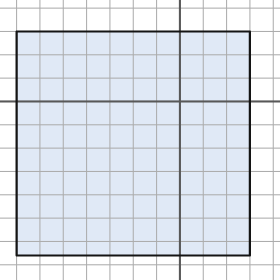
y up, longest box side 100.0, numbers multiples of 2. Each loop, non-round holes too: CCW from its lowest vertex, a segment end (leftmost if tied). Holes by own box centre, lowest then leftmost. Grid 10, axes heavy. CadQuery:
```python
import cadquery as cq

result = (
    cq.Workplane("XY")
    .moveTo(-70.0, -66.0)
    .lineTo(30.0, -66.0)
    .lineTo(30.0, 30.0)
    .lineTo(-70.0, 30.0)
    .close()
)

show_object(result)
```